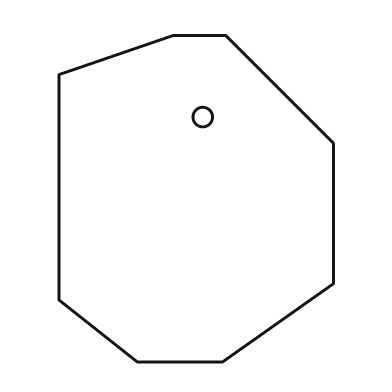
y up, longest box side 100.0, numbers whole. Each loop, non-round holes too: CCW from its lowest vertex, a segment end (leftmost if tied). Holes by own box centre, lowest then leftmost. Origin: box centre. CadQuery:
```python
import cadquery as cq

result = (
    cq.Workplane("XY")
    .moveTo(-18.0, -50.0)
    .lineTo(8.0, -50.0)
    .lineTo(42.0, -26.0)
    .lineTo(42.0, 17.0)
    .lineTo(9.0, 50.0)
    .lineTo(-7.0, 50.0)
    .lineTo(-42.0, 38.0)
    .lineTo(-42.0, -31.0)
    .close()
    .moveTo(2.0, 25.0)
    .circle(3.0)
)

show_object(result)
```